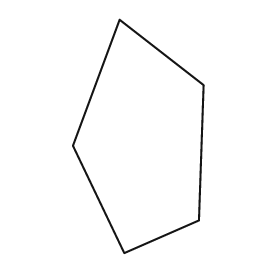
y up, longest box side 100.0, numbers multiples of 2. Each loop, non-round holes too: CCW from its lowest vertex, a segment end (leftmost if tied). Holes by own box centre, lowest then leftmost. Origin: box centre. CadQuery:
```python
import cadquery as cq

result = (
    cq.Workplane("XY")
    .moveTo(-6.0, -50.0)
    .lineTo(26.0, -36.0)
    .lineTo(28.0, 22.0)
    .lineTo(-8.0, 50.0)
    .lineTo(-28.0, -4.0)
    .close()
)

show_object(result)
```